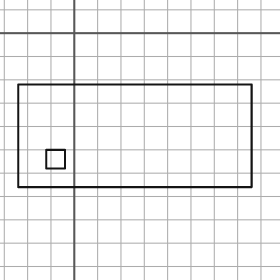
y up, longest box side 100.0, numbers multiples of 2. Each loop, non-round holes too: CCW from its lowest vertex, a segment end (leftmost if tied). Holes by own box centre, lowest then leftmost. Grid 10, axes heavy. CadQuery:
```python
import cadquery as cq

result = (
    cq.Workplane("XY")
    .moveTo(-24.0, -66.0)
    .lineTo(76.0, -66.0)
    .lineTo(76.0, -22.0)
    .lineTo(-24.0, -22.0)
    .close()
    .moveTo(-12.0, -58.0)
    .lineTo(-4.0, -58.0)
    .lineTo(-4.0, -50.0)
    .lineTo(-12.0, -50.0)
    .close()
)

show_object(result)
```